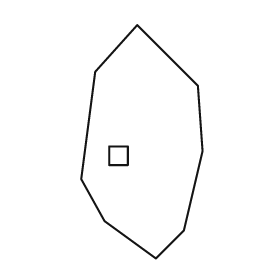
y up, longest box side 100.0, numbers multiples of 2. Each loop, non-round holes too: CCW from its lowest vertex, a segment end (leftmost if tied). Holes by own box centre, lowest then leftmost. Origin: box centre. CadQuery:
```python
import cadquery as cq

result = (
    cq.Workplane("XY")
    .moveTo(6.0, -50.0)
    .lineTo(18.0, -38.0)
    .lineTo(26.0, -4.0)
    .lineTo(24.0, 24.0)
    .lineTo(-2.0, 50.0)
    .lineTo(-20.0, 30.0)
    .lineTo(-26.0, -16.0)
    .lineTo(-16.0, -34.0)
    .close()
    .moveTo(-14.0, -10.0)
    .lineTo(-6.0, -10.0)
    .lineTo(-6.0, -2.0)
    .lineTo(-14.0, -2.0)
    .close()
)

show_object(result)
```